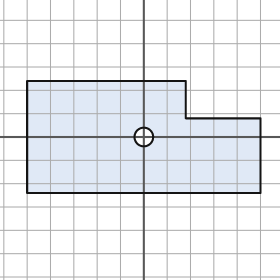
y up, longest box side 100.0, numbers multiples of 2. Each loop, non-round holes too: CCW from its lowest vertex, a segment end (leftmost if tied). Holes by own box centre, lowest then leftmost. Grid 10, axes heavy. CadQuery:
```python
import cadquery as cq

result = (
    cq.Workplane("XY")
    .moveTo(-50.0, -24.0)
    .lineTo(50.0, -24.0)
    .lineTo(50.0, 8.0)
    .lineTo(18.0, 8.0)
    .lineTo(18.0, 24.0)
    .lineTo(-50.0, 24.0)
    .close()
    .moveTo(0.0, 0.0)
    .circle(4.0)
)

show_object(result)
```